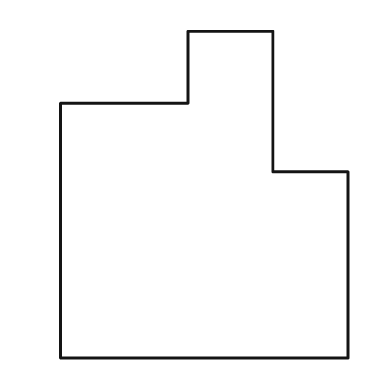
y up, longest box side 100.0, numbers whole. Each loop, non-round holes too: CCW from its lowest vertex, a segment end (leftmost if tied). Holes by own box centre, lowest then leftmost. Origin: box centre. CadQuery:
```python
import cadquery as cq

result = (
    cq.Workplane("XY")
    .moveTo(-44.0, -50.0)
    .lineTo(44.0, -50.0)
    .lineTo(44.0, 7.0)
    .lineTo(21.0, 7.0)
    .lineTo(21.0, 50.0)
    .lineTo(-5.0, 50.0)
    .lineTo(-5.0, 28.0)
    .lineTo(-44.0, 28.0)
    .close()
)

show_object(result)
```